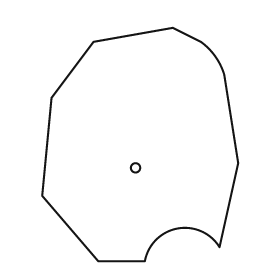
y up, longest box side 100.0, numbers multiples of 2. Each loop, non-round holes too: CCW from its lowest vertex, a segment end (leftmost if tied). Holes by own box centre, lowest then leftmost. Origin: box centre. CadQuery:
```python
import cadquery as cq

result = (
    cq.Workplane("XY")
    .moveTo(-18.0, -50.0)
    .lineTo(2.0, -50.0)
    .threePointArc((16.0, -36.0), (34.0, -44.0))
    .lineTo(42.0, -8.0)
    .lineTo(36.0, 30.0)
    .threePointArc((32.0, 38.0), (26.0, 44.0))
    .lineTo(14.0, 50.0)
    .lineTo(-20.0, 44.0)
    .lineTo(-38.0, 20.0)
    .lineTo(-42.0, -22.0)
    .close()
    .moveTo(-2.0, -10.0)
    .circle(2.0)
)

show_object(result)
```